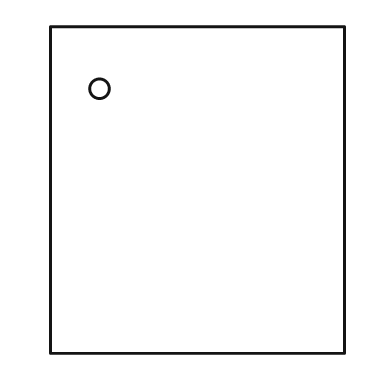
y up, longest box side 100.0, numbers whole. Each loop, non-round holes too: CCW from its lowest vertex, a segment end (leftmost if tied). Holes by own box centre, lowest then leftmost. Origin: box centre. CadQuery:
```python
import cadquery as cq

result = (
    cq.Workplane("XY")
    .moveTo(-45.0, -50.0)
    .lineTo(45.0, -50.0)
    .lineTo(45.0, 50.0)
    .lineTo(-45.0, 50.0)
    .close()
    .moveTo(-30.0, 31.0)
    .circle(3.0)
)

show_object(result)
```